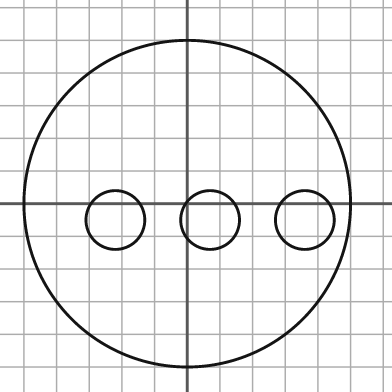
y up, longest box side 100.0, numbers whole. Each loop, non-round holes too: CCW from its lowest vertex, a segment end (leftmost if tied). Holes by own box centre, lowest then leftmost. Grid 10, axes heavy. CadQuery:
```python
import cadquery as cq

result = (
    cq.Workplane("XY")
    .moveTo(0.0, 0.0)
    .circle(50.0)
    .moveTo(-22.0, -5.0)
    .circle(9.0)
    .moveTo(7.0, -5.0)
    .circle(9.0)
    .moveTo(36.0, -5.0)
    .circle(9.0)
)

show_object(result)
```